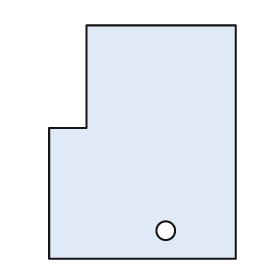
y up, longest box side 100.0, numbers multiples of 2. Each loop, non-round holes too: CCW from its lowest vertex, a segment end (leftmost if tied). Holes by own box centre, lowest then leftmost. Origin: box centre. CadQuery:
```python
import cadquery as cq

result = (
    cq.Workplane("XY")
    .moveTo(-40.0, -50.0)
    .lineTo(40.0, -50.0)
    .lineTo(40.0, 50.0)
    .lineTo(-24.0, 50.0)
    .lineTo(-24.0, 6.0)
    .lineTo(-40.0, 6.0)
    .close()
    .moveTo(10.0, -38.0)
    .circle(4.0)
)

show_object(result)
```